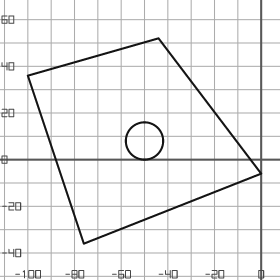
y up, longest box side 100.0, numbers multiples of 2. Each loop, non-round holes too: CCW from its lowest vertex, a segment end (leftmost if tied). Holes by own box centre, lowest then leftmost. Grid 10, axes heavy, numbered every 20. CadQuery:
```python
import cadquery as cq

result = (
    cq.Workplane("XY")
    .moveTo(-76.0, -36.0)
    .lineTo(0.0, -6.0)
    .lineTo(-44.0, 52.0)
    .lineTo(-100.0, 36.0)
    .close()
    .moveTo(-50.0, 8.0)
    .circle(8.0)
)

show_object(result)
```